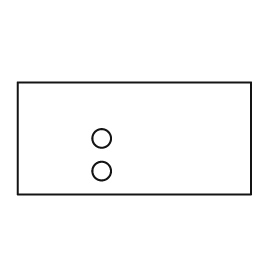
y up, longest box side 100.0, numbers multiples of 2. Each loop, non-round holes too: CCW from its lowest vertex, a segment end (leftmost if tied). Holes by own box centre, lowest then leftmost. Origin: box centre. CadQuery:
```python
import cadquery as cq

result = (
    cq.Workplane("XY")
    .moveTo(-50.0, -24.0)
    .lineTo(50.0, -24.0)
    .lineTo(50.0, 24.0)
    .lineTo(-50.0, 24.0)
    .close()
    .moveTo(-14.0, -14.0)
    .circle(4.0)
    .moveTo(-14.0, 0.0)
    .circle(4.0)
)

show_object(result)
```